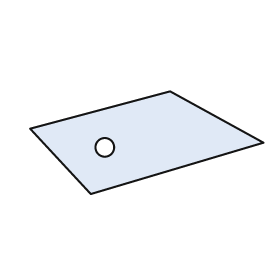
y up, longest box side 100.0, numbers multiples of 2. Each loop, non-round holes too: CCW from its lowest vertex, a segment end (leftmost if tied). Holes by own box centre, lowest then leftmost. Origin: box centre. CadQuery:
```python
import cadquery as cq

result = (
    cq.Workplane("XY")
    .moveTo(-24.0, -22.0)
    .lineTo(50.0, 0.0)
    .lineTo(10.0, 22.0)
    .lineTo(-50.0, 6.0)
    .close()
    .moveTo(-18.0, -2.0)
    .circle(4.0)
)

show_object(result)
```